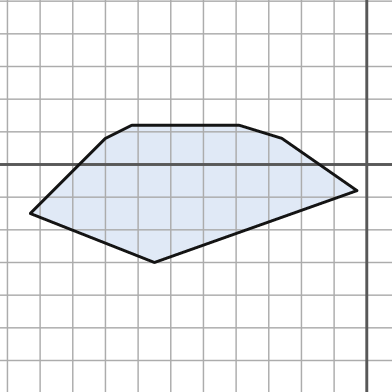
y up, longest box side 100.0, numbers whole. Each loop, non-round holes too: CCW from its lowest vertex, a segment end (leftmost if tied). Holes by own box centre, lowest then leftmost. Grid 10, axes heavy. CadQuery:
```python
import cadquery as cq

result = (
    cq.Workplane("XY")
    .moveTo(-65.0, -30.0)
    .lineTo(-3.0, -8.0)
    .lineTo(-26.0, 8.0)
    .lineTo(-39.0, 12.0)
    .lineTo(-72.0, 12.0)
    .lineTo(-80.0, 8.0)
    .lineTo(-103.0, -15.0)
    .close()
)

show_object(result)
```